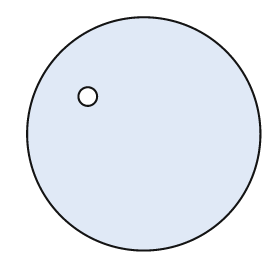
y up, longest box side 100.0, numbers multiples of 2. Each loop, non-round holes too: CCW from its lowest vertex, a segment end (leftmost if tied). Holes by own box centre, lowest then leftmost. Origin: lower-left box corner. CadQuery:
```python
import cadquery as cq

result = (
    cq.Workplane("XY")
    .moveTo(50.0, 50.0)
    .circle(50.0)
    .moveTo(26.0, 66.0)
    .circle(4.0)
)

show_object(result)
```